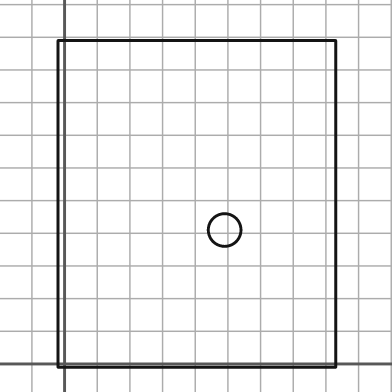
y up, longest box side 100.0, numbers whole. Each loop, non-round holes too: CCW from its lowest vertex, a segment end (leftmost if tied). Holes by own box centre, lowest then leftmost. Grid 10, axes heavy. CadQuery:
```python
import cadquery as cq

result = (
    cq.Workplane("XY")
    .moveTo(-2.0, -1.0)
    .lineTo(83.0, -1.0)
    .lineTo(83.0, 99.0)
    .lineTo(-2.0, 99.0)
    .close()
    .moveTo(49.0, 41.0)
    .circle(5.0)
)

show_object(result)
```